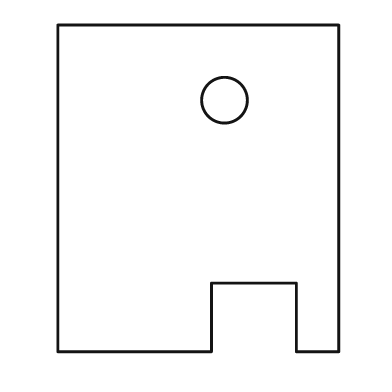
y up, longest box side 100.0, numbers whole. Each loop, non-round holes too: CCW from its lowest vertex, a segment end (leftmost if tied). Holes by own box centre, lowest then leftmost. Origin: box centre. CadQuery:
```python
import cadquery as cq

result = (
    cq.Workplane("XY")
    .moveTo(-43.0, -50.0)
    .lineTo(4.0, -50.0)
    .lineTo(4.0, -29.0)
    .lineTo(30.0, -29.0)
    .lineTo(30.0, -50.0)
    .lineTo(43.0, -50.0)
    .lineTo(43.0, 50.0)
    .lineTo(-43.0, 50.0)
    .close()
    .moveTo(8.0, 27.0)
    .circle(7.0)
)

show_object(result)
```